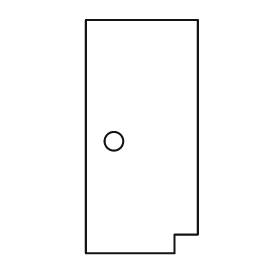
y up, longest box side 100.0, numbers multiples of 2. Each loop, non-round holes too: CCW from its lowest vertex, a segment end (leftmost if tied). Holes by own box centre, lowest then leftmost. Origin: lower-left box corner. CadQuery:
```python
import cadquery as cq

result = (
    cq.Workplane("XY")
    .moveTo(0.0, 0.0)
    .lineTo(38.0, 0.0)
    .lineTo(38.0, 8.0)
    .lineTo(48.0, 8.0)
    .lineTo(48.0, 100.0)
    .lineTo(0.0, 100.0)
    .close()
    .moveTo(12.0, 48.0)
    .circle(4.0)
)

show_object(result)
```